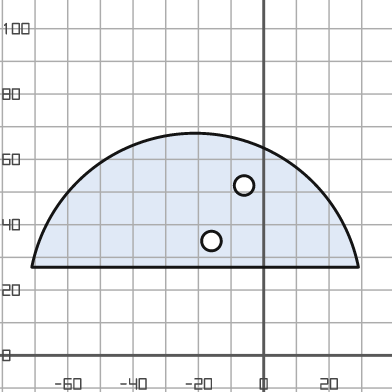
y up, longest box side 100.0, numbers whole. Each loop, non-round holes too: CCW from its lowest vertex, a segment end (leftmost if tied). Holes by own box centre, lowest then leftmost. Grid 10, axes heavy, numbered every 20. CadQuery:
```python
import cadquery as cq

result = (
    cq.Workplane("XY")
    .moveTo(-71.0, 27.0)
    .lineTo(29.0, 27.0)
    .threePointArc((-21.0, 68.0), (-71.0, 27.0))
    .close()
    .moveTo(-16.0, 35.0)
    .circle(3.0)
    .moveTo(-6.0, 52.0)
    .circle(3.0)
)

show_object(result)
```